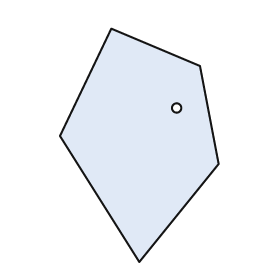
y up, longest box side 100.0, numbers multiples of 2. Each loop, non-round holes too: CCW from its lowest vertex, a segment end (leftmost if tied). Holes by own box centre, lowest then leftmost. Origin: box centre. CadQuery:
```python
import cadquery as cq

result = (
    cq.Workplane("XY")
    .moveTo(0.0, -50.0)
    .lineTo(34.0, -8.0)
    .lineTo(26.0, 34.0)
    .lineTo(-12.0, 50.0)
    .lineTo(-34.0, 4.0)
    .close()
    .moveTo(16.0, 16.0)
    .circle(2.0)
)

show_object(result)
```